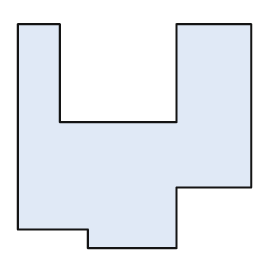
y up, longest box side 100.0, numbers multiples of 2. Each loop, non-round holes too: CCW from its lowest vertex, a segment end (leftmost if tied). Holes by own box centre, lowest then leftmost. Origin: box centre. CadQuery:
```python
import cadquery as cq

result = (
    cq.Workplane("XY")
    .moveTo(-20.0, -48.0)
    .lineTo(18.0, -48.0)
    .lineTo(18.0, -22.0)
    .lineTo(50.0, -22.0)
    .lineTo(50.0, 48.0)
    .lineTo(18.0, 48.0)
    .lineTo(18.0, 6.0)
    .lineTo(-32.0, 6.0)
    .lineTo(-32.0, 48.0)
    .lineTo(-50.0, 48.0)
    .lineTo(-50.0, -40.0)
    .lineTo(-20.0, -40.0)
    .close()
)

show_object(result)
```